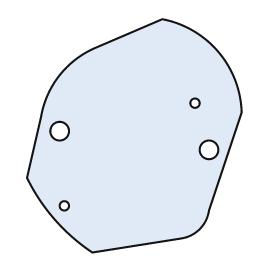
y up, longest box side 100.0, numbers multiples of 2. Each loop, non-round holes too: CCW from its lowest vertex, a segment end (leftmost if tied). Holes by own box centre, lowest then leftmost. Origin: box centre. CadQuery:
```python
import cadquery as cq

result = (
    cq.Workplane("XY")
    .moveTo(-18.0, -50.0)
    .lineTo(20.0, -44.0)
    .threePointArc((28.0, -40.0), (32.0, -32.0))
    .lineTo(46.0, 10.0)
    .threePointArc((36.0, 36.0), (12.0, 50.0))
    .lineTo(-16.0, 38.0)
    .threePointArc((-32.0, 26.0), (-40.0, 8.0))
    .lineTo(-46.0, -18.0)
    .threePointArc((-34.0, -36.0), (-18.0, -50.0))
    .close()
    .moveTo(-30.0, -30.0)
    .circle(2.0)
    .moveTo(32.0, -6.0)
    .circle(4.0)
    .moveTo(-32.0, 2.0)
    .circle(4.0)
    .moveTo(26.0, 14.0)
    .circle(2.0)
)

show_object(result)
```